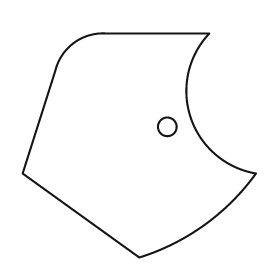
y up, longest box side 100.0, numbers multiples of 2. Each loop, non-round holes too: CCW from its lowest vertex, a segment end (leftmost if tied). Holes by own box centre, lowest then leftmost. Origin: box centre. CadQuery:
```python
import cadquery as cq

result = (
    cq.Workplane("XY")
    .moveTo(0.0, -48.0)
    .threePointArc((28.0, -34.0), (50.0, -12.0))
    .threePointArc((22.0, 12.0), (30.0, 48.0))
    .lineTo(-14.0, 48.0)
    .threePointArc((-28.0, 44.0), (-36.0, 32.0))
    .lineTo(-50.0, -12.0)
    .close()
    .moveTo(12.0, 8.0)
    .circle(4.0)
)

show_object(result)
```